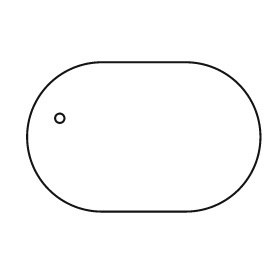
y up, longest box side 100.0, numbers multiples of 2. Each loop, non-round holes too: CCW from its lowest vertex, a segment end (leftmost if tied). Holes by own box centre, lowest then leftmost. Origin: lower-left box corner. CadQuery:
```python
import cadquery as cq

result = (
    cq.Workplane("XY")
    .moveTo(32.0, 0.0)
    .lineTo(68.0, 0.0)
    .threePointArc((100.0, 32.0), (68.0, 64.0))
    .lineTo(32.0, 64.0)
    .threePointArc((0.0, 32.0), (32.0, 0.0))
    .close()
    .moveTo(14.0, 40.0)
    .circle(2.0)
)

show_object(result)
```